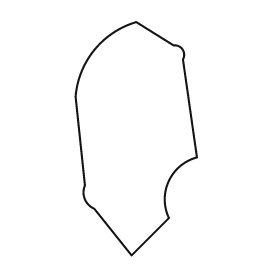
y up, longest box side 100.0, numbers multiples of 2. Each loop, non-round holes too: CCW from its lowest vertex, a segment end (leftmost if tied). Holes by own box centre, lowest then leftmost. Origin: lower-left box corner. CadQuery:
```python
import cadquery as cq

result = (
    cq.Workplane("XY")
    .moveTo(24.0, 0.0)
    .lineTo(40.0, 16.0)
    .threePointArc((40.0, 32.0), (52.0, 42.0))
    .lineTo(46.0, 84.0)
    .threePointArc((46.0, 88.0), (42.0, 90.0))
    .lineTo(26.0, 100.0)
    .threePointArc((8.0, 88.0), (0.0, 68.0))
    .lineTo(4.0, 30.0)
    .threePointArc((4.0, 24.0), (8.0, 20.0))
    .close()
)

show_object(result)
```